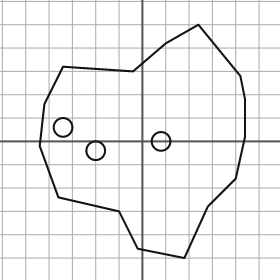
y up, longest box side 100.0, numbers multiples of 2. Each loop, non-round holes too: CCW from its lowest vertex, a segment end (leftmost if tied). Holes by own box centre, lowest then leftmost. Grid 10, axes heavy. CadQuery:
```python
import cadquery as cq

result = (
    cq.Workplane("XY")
    .moveTo(18.0, -50.0)
    .lineTo(28.0, -28.0)
    .lineTo(40.0, -16.0)
    .lineTo(44.0, 2.0)
    .lineTo(44.0, 18.0)
    .lineTo(42.0, 28.0)
    .lineTo(24.0, 50.0)
    .lineTo(10.0, 42.0)
    .lineTo(-4.0, 30.0)
    .lineTo(-34.0, 32.0)
    .lineTo(-42.0, 16.0)
    .lineTo(-44.0, -2.0)
    .lineTo(-36.0, -24.0)
    .lineTo(-10.0, -30.0)
    .lineTo(-2.0, -46.0)
    .close()
    .moveTo(-20.0, -4.0)
    .circle(4.0)
    .moveTo(8.0, 0.0)
    .circle(4.0)
    .moveTo(-34.0, 6.0)
    .circle(4.0)
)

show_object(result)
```